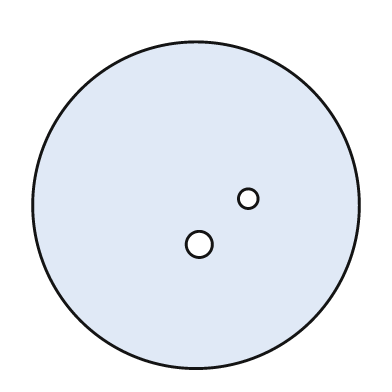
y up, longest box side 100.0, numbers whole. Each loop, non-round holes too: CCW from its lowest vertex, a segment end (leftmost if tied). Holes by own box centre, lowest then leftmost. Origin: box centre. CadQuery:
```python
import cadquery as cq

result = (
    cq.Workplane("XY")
    .moveTo(0.0, 0.0)
    .circle(50.0)
    .moveTo(1.0, -12.0)
    .circle(4.0)
    .moveTo(16.0, 2.0)
    .circle(3.0)
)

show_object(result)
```